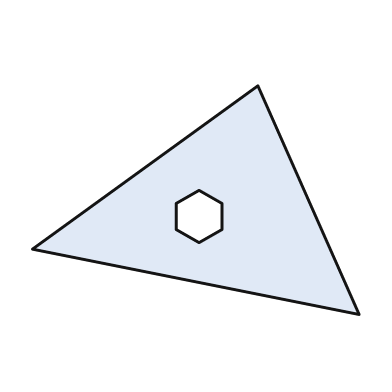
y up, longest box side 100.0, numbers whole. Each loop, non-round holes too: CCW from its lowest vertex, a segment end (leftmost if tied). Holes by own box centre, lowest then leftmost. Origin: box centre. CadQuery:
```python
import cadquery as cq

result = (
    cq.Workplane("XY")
    .moveTo(50.0, -35.0)
    .lineTo(19.0, 35.0)
    .lineTo(-50.0, -15.0)
    .close()
    .moveTo(1.0, -13.0)
    .lineTo(8.0, -9.0)
    .lineTo(8.0, -1.0)
    .lineTo(1.0, 3.0)
    .lineTo(-6.0, -1.0)
    .lineTo(-6.0, -9.0)
    .close()
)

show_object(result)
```